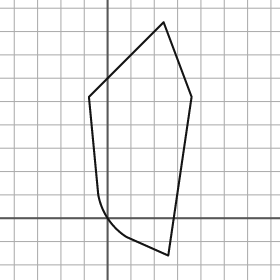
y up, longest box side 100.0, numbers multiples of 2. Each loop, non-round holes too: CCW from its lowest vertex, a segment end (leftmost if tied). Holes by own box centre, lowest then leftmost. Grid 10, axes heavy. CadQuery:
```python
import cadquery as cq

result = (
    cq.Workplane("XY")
    .moveTo(26.0, -16.0)
    .lineTo(36.0, 52.0)
    .lineTo(24.0, 84.0)
    .lineTo(-8.0, 52.0)
    .lineTo(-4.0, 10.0)
    .threePointArc((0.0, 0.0), (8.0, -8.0))
    .close()
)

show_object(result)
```